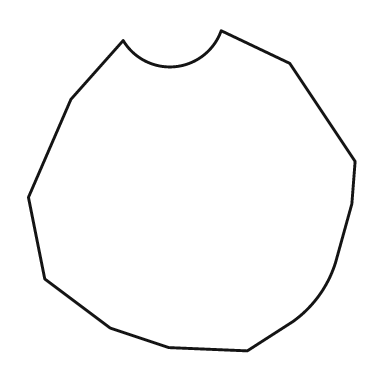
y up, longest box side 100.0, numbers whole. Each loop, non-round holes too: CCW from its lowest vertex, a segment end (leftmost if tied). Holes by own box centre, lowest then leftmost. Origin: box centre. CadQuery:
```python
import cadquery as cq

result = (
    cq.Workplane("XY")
    .moveTo(17.0, -49.0)
    .lineTo(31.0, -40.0)
    .threePointArc((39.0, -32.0), (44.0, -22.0))
    .lineTo(49.0, -4.0)
    .lineTo(50.0, 9.0)
    .lineTo(30.0, 39.0)
    .lineTo(9.0, 49.0)
    .threePointArc((-5.0, 38.0), (-21.0, 46.0))
    .lineTo(-37.0, 28.0)
    .lineTo(-50.0, -2.0)
    .lineTo(-45.0, -27.0)
    .lineTo(-25.0, -42.0)
    .lineTo(-7.0, -48.0)
    .close()
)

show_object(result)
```